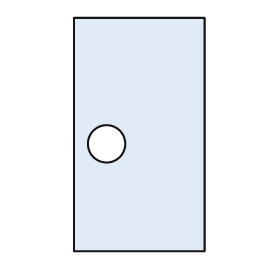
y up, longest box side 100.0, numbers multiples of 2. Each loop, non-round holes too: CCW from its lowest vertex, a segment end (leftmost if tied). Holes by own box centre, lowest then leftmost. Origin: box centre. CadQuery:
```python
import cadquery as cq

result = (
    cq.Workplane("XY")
    .moveTo(-28.0, -50.0)
    .lineTo(28.0, -50.0)
    .lineTo(28.0, 50.0)
    .lineTo(-28.0, 50.0)
    .close()
    .moveTo(-14.0, -4.0)
    .circle(8.0)
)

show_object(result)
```